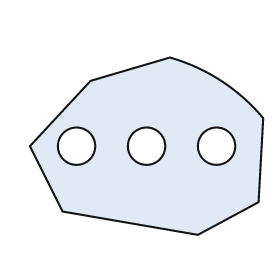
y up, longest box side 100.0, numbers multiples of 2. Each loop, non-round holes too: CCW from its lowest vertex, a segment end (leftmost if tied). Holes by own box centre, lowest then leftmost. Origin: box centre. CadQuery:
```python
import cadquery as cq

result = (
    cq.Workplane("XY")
    .moveTo(22.0, -38.0)
    .lineTo(48.0, -24.0)
    .lineTo(50.0, 12.0)
    .threePointArc((32.0, 28.0), (10.0, 38.0))
    .lineTo(-24.0, 28.0)
    .lineTo(-50.0, 0.0)
    .lineTo(-36.0, -28.0)
    .close()
    .moveTo(-30.0, 0.0)
    .circle(8.0)
    .moveTo(0.0, 0.0)
    .circle(8.0)
    .moveTo(30.0, 0.0)
    .circle(8.0)
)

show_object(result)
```